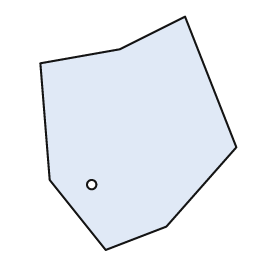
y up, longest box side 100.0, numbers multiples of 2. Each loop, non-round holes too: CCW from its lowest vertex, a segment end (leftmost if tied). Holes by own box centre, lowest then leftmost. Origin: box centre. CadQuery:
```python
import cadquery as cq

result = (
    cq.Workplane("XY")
    .moveTo(-14.0, -50.0)
    .lineTo(12.0, -40.0)
    .lineTo(42.0, -6.0)
    .lineTo(20.0, 50.0)
    .lineTo(-8.0, 36.0)
    .lineTo(-42.0, 30.0)
    .lineTo(-38.0, -20.0)
    .close()
    .moveTo(-20.0, -22.0)
    .circle(2.0)
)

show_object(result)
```